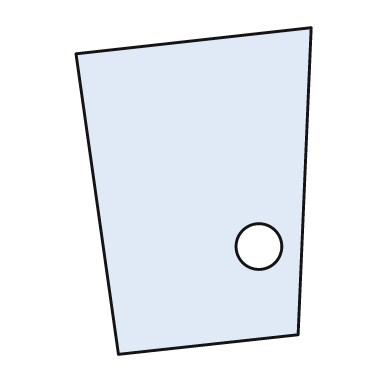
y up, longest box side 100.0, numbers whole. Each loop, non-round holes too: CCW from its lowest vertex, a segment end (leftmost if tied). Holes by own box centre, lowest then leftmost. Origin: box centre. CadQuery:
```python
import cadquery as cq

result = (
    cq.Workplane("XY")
    .moveTo(-23.0, -50.0)
    .lineTo(32.0, -44.0)
    .lineTo(36.0, 50.0)
    .lineTo(-36.0, 42.0)
    .close()
    .moveTo(20.0, -17.0)
    .circle(7.0)
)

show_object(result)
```